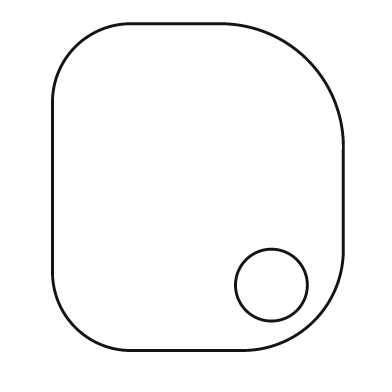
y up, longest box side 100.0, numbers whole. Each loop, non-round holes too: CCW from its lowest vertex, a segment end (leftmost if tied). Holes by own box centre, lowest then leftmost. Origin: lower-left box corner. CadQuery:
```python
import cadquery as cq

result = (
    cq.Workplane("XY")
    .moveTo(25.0, 0.0)
    .lineTo(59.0, 0.0)
    .threePointArc((80.0, 9.0), (89.0, 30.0))
    .lineTo(89.0, 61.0)
    .threePointArc((78.0, 89.0), (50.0, 100.0))
    .lineTo(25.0, 100.0)
    .threePointArc((7.0, 93.0), (0.0, 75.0))
    .lineTo(0.0, 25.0)
    .threePointArc((7.0, 7.0), (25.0, 0.0))
    .close()
    .moveTo(67.0, 20.0)
    .circle(11.0)
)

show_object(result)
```